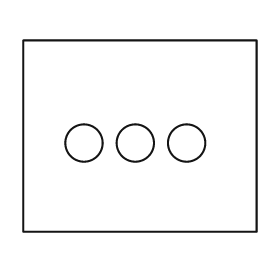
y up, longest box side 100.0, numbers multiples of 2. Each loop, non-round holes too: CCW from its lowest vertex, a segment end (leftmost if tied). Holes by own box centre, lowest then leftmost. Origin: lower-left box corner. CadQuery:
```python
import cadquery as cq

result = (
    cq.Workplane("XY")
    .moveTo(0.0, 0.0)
    .lineTo(100.0, 0.0)
    .lineTo(100.0, 82.0)
    .lineTo(0.0, 82.0)
    .close()
    .moveTo(26.0, 38.0)
    .circle(8.0)
    .moveTo(48.0, 38.0)
    .circle(8.0)
    .moveTo(70.0, 38.0)
    .circle(8.0)
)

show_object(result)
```